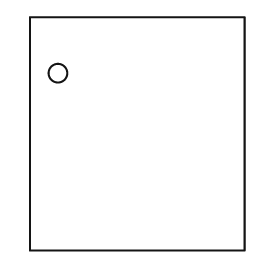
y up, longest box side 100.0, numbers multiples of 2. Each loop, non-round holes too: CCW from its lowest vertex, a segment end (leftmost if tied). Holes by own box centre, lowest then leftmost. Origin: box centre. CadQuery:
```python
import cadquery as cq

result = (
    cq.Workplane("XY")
    .moveTo(-46.0, -50.0)
    .lineTo(46.0, -50.0)
    .lineTo(46.0, 50.0)
    .lineTo(-46.0, 50.0)
    .close()
    .moveTo(-34.0, 26.0)
    .circle(4.0)
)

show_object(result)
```